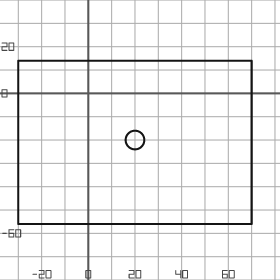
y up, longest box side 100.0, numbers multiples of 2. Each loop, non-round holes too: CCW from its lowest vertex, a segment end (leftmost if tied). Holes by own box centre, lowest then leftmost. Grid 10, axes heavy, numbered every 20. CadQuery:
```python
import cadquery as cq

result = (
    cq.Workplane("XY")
    .moveTo(-30.0, -56.0)
    .lineTo(70.0, -56.0)
    .lineTo(70.0, 14.0)
    .lineTo(-30.0, 14.0)
    .close()
    .moveTo(20.0, -20.0)
    .circle(4.0)
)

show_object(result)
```